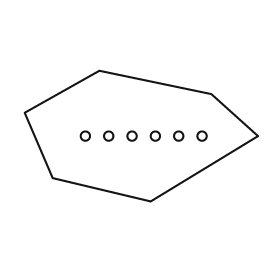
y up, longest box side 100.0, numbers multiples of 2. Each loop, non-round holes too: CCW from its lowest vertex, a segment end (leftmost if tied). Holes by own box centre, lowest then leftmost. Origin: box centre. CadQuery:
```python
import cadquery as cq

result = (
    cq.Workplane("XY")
    .moveTo(4.0, -28.0)
    .lineTo(50.0, 0.0)
    .lineTo(30.0, 18.0)
    .lineTo(-18.0, 28.0)
    .lineTo(-50.0, 10.0)
    .lineTo(-38.0, -18.0)
    .close()
    .moveTo(-24.0, 0.0)
    .circle(2.0)
    .moveTo(-14.0, 0.0)
    .circle(2.0)
    .moveTo(-4.0, 0.0)
    .circle(2.0)
    .moveTo(6.0, 0.0)
    .circle(2.0)
    .moveTo(16.0, 0.0)
    .circle(2.0)
    .moveTo(26.0, 0.0)
    .circle(2.0)
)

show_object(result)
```